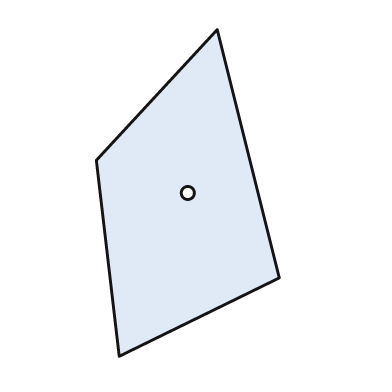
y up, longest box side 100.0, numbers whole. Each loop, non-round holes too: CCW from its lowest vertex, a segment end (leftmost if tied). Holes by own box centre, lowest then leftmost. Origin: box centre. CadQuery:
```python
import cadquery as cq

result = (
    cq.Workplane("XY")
    .moveTo(-21.0, -50.0)
    .lineTo(28.0, -26.0)
    .lineTo(9.0, 50.0)
    .lineTo(-28.0, 10.0)
    .close()
    .moveTo(0.0, 0.0)
    .circle(2.0)
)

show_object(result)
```